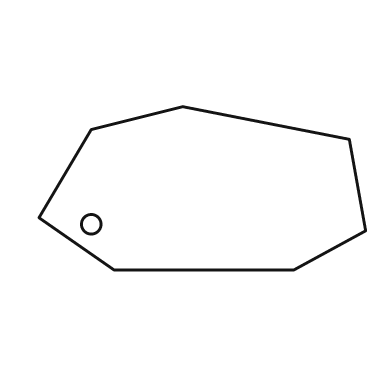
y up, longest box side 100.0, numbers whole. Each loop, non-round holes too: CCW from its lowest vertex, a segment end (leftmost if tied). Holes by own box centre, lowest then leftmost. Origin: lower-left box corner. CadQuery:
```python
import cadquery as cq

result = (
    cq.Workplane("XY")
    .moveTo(23.0, 0.0)
    .lineTo(78.0, 0.0)
    .lineTo(100.0, 12.0)
    .lineTo(95.0, 40.0)
    .lineTo(44.0, 50.0)
    .lineTo(16.0, 43.0)
    .lineTo(0.0, 16.0)
    .close()
    .moveTo(16.0, 14.0)
    .circle(3.0)
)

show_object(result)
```